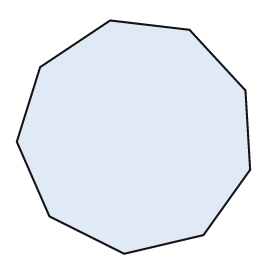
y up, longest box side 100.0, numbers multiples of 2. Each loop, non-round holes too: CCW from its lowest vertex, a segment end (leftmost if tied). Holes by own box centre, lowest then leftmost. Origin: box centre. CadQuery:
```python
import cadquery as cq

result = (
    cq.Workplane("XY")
    .moveTo(-4.0, -50.0)
    .lineTo(30.0, -42.0)
    .lineTo(50.0, -14.0)
    .lineTo(48.0, 20.0)
    .lineTo(24.0, 46.0)
    .lineTo(-10.0, 50.0)
    .lineTo(-40.0, 30.0)
    .lineTo(-50.0, -2.0)
    .lineTo(-36.0, -34.0)
    .close()
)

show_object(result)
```